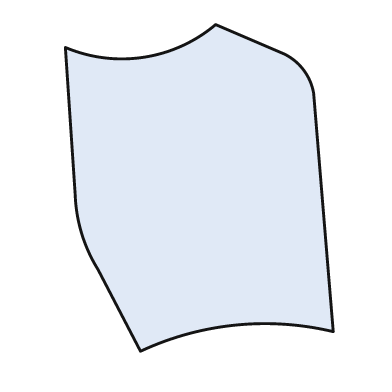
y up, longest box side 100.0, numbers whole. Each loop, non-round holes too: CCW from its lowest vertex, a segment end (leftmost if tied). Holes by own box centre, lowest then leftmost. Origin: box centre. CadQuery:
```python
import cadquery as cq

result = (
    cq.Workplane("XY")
    .moveTo(-18.0, -50.0)
    .threePointArc((11.0, -42.0), (41.0, -44.0))
    .lineTo(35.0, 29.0)
    .threePointArc((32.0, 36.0), (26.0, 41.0))
    .lineTo(5.0, 50.0)
    .threePointArc((-17.0, 40.0), (-41.0, 43.0))
    .lineTo(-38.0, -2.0)
    .threePointArc((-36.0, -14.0), (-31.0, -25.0))
    .close()
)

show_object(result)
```